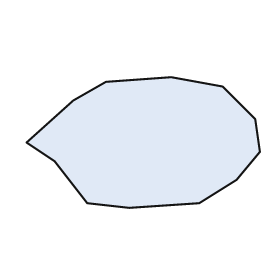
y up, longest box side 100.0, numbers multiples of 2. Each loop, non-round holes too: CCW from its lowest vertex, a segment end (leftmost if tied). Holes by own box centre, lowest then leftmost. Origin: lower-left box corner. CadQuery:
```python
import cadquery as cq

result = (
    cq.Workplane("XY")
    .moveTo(44.0, 0.0)
    .lineTo(74.0, 2.0)
    .lineTo(90.0, 12.0)
    .lineTo(100.0, 24.0)
    .lineTo(98.0, 38.0)
    .lineTo(84.0, 52.0)
    .lineTo(62.0, 56.0)
    .lineTo(34.0, 54.0)
    .lineTo(20.0, 46.0)
    .lineTo(0.0, 28.0)
    .lineTo(12.0, 20.0)
    .lineTo(26.0, 2.0)
    .close()
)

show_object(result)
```